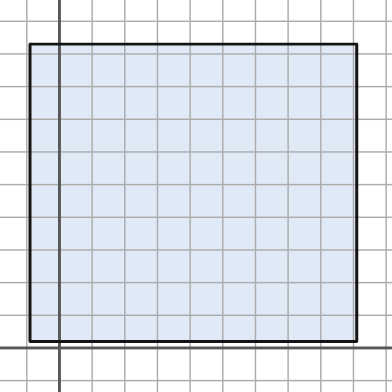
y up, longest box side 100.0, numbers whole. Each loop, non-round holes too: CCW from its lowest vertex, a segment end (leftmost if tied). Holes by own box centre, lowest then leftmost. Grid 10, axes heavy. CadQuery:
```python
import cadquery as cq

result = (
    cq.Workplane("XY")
    .moveTo(-9.0, 2.0)
    .lineTo(91.0, 2.0)
    .lineTo(91.0, 93.0)
    .lineTo(-9.0, 93.0)
    .close()
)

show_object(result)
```